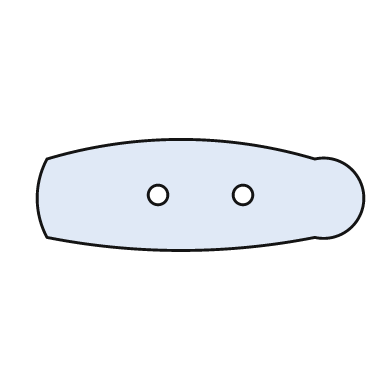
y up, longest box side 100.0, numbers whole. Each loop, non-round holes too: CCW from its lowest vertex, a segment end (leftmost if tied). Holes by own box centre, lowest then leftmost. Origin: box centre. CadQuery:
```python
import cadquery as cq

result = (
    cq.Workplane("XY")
    .moveTo(-47.0, -13.0)
    .threePointArc((-6.0, -17.0), (35.0, -13.0))
    .threePointArc((50.0, -1.0), (35.0, 11.0))
    .threePointArc((-6.0, 17.0), (-47.0, 11.0))
    .threePointArc((-50.0, -1.0), (-47.0, -13.0))
    .close()
    .moveTo(-13.0, 0.0)
    .circle(3.0)
    .moveTo(13.0, 0.0)
    .circle(3.0)
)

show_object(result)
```